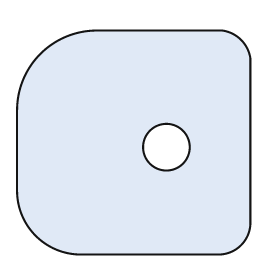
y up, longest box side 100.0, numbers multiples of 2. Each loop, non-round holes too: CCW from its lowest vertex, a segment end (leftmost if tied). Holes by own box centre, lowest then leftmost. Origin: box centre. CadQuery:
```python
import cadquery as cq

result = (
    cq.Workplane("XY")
    .moveTo(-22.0, -48.0)
    .lineTo(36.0, -48.0)
    .threePointArc((46.0, -44.0), (50.0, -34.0))
    .lineTo(50.0, 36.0)
    .threePointArc((46.0, 44.0), (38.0, 48.0))
    .lineTo(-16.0, 48.0)
    .threePointArc((-40.0, 38.0), (-50.0, 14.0))
    .lineTo(-50.0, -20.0)
    .threePointArc((-42.0, -40.0), (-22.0, -48.0))
    .close()
    .moveTo(14.0, -2.0)
    .circle(10.0)
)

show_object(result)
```